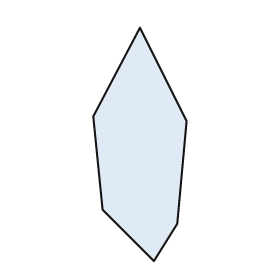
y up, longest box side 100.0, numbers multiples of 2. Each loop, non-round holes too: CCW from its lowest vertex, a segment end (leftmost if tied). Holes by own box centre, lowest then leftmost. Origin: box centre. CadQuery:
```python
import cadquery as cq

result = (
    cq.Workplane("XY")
    .moveTo(6.0, -50.0)
    .lineTo(16.0, -34.0)
    .lineTo(20.0, 10.0)
    .lineTo(0.0, 50.0)
    .lineTo(-20.0, 12.0)
    .lineTo(-16.0, -28.0)
    .close()
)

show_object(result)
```